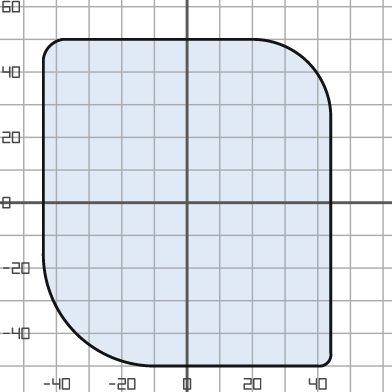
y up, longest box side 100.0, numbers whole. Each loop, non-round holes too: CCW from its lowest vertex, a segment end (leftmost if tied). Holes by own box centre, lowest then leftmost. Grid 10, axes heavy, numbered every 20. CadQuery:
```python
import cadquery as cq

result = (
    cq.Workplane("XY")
    .moveTo(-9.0, -50.0)
    .lineTo(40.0, -50.0)
    .threePointArc((43.0, -49.0), (44.0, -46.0))
    .lineTo(44.0, 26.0)
    .threePointArc((37.0, 43.0), (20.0, 50.0))
    .lineTo(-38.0, 50.0)
    .threePointArc((-42.0, 48.0), (-44.0, 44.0))
    .lineTo(-44.0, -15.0)
    .threePointArc((-34.0, -40.0), (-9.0, -50.0))
    .close()
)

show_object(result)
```